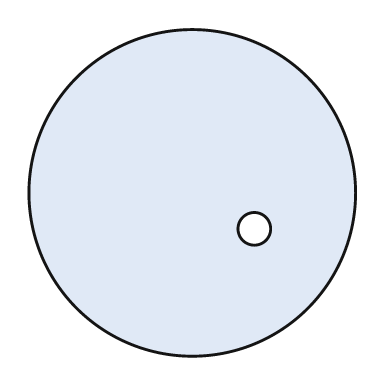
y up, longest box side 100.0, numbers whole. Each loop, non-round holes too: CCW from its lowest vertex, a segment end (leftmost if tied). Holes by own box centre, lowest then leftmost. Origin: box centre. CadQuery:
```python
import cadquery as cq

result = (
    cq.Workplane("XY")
    .moveTo(0.0, 0.0)
    .circle(50.0)
    .moveTo(19.0, -11.0)
    .circle(5.0)
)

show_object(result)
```